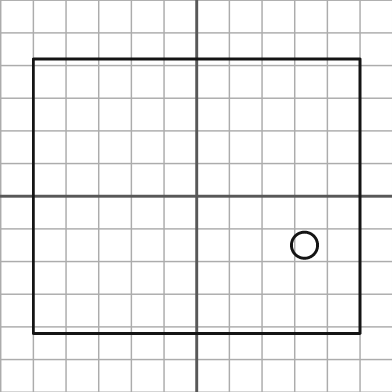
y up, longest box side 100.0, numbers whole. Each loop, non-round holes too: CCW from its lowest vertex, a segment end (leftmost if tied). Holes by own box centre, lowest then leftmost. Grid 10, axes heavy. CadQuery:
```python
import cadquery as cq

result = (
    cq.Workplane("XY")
    .moveTo(-50.0, -42.0)
    .lineTo(50.0, -42.0)
    .lineTo(50.0, 42.0)
    .lineTo(-50.0, 42.0)
    .close()
    .moveTo(33.0, -15.0)
    .circle(4.0)
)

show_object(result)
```